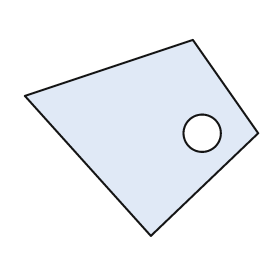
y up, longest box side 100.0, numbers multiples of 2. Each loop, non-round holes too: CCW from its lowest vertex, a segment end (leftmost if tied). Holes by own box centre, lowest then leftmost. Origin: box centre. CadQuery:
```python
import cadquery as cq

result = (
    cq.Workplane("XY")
    .moveTo(4.0, -42.0)
    .lineTo(50.0, 2.0)
    .lineTo(22.0, 42.0)
    .lineTo(-50.0, 18.0)
    .close()
    .moveTo(26.0, 2.0)
    .circle(8.0)
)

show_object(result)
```